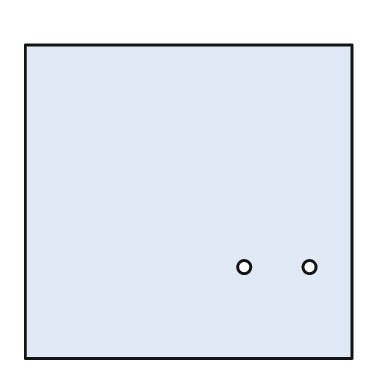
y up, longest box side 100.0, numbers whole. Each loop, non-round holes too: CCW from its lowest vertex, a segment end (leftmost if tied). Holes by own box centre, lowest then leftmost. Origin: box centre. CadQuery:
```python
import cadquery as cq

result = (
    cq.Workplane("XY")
    .moveTo(-50.0, -48.0)
    .lineTo(50.0, -48.0)
    .lineTo(50.0, 48.0)
    .lineTo(-50.0, 48.0)
    .close()
    .moveTo(17.0, -20.0)
    .circle(2.0)
    .moveTo(37.0, -20.0)
    .circle(2.0)
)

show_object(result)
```